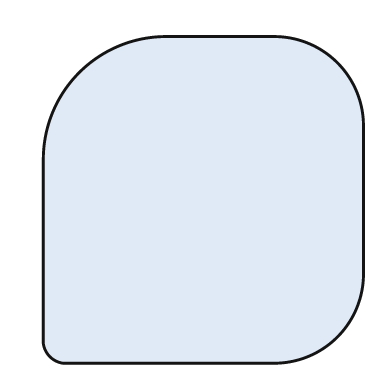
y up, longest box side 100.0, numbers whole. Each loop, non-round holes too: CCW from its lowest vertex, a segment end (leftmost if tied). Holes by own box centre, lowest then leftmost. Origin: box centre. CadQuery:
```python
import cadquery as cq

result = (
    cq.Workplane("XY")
    .moveTo(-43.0, -50.0)
    .lineTo(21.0, -50.0)
    .threePointArc((41.0, -42.0), (49.0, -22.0))
    .lineTo(49.0, 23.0)
    .threePointArc((41.0, 42.0), (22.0, 50.0))
    .lineTo(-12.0, 50.0)
    .threePointArc((-38.0, 39.0), (-49.0, 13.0))
    .lineTo(-49.0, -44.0)
    .threePointArc((-47.0, -48.0), (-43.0, -50.0))
    .close()
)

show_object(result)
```